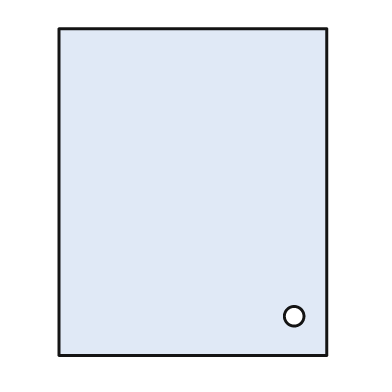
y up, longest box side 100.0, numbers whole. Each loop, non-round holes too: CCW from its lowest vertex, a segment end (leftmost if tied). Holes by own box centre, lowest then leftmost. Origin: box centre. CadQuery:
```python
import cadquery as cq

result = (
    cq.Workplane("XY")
    .moveTo(-41.0, -50.0)
    .lineTo(41.0, -50.0)
    .lineTo(41.0, 50.0)
    .lineTo(-41.0, 50.0)
    .close()
    .moveTo(31.0, -38.0)
    .circle(3.0)
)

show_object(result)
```